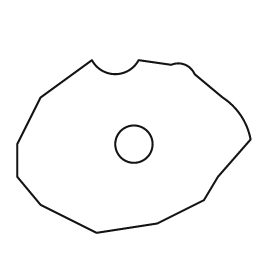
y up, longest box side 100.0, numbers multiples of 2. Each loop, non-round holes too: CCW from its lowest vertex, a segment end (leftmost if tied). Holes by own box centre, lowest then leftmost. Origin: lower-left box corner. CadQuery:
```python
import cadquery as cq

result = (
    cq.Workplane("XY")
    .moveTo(34.0, 0.0)
    .lineTo(60.0, 4.0)
    .lineTo(80.0, 14.0)
    .lineTo(86.0, 24.0)
    .lineTo(100.0, 40.0)
    .threePointArc((96.0, 50.0), (88.0, 58.0))
    .lineTo(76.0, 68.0)
    .threePointArc((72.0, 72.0), (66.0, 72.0))
    .lineTo(52.0, 74.0)
    .threePointArc((42.0, 68.0), (32.0, 74.0))
    .lineTo(10.0, 58.0)
    .lineTo(0.0, 38.0)
    .lineTo(0.0, 24.0)
    .lineTo(10.0, 12.0)
    .close()
    .moveTo(50.0, 38.0)
    .circle(8.0)
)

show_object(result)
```